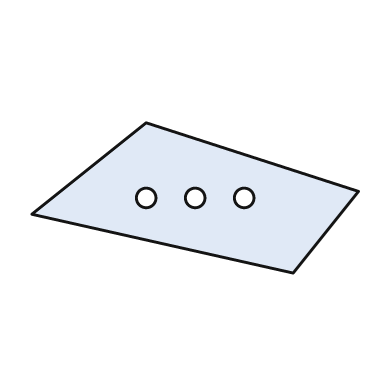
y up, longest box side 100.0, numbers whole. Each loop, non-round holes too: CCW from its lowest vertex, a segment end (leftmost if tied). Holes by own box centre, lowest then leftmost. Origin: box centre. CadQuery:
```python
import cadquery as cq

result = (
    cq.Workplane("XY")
    .moveTo(30.0, -23.0)
    .lineTo(50.0, 2.0)
    .lineTo(-15.0, 23.0)
    .lineTo(-50.0, -5.0)
    .close()
    .moveTo(-15.0, 0.0)
    .circle(3.0)
    .moveTo(0.0, 0.0)
    .circle(3.0)
    .moveTo(15.0, 0.0)
    .circle(3.0)
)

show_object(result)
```